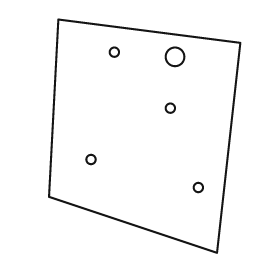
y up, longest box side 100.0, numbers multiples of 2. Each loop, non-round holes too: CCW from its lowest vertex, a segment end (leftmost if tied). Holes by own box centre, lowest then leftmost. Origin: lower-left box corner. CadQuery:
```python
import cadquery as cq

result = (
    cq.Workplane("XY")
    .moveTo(72.0, 0.0)
    .lineTo(82.0, 90.0)
    .lineTo(4.0, 100.0)
    .lineTo(0.0, 24.0)
    .close()
    .moveTo(64.0, 28.0)
    .circle(2.0)
    .moveTo(18.0, 40.0)
    .circle(2.0)
    .moveTo(52.0, 62.0)
    .circle(2.0)
    .moveTo(54.0, 84.0)
    .circle(4.0)
    .moveTo(28.0, 86.0)
    .circle(2.0)
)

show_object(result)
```